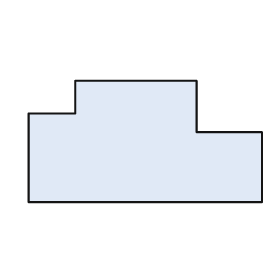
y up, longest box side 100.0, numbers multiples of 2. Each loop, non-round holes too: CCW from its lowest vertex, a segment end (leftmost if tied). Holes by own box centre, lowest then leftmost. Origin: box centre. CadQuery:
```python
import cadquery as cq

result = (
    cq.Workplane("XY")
    .moveTo(-50.0, -26.0)
    .lineTo(50.0, -26.0)
    .lineTo(50.0, 4.0)
    .lineTo(22.0, 4.0)
    .lineTo(22.0, 26.0)
    .lineTo(-30.0, 26.0)
    .lineTo(-30.0, 12.0)
    .lineTo(-50.0, 12.0)
    .close()
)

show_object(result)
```